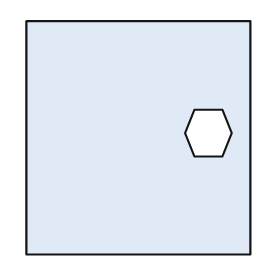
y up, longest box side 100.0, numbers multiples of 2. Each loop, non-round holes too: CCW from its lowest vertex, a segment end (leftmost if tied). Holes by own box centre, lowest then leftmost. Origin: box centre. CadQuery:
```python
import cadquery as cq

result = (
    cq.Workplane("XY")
    .moveTo(-48.0, -50.0)
    .lineTo(48.0, -50.0)
    .lineTo(48.0, 50.0)
    .lineTo(-48.0, 50.0)
    .close()
    .moveTo(24.0, -8.0)
    .lineTo(36.0, -8.0)
    .lineTo(40.0, 2.0)
    .lineTo(36.0, 12.0)
    .lineTo(24.0, 12.0)
    .lineTo(20.0, 2.0)
    .close()
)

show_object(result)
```